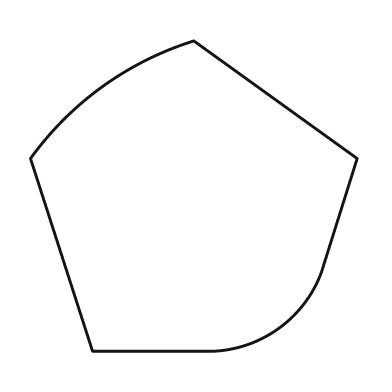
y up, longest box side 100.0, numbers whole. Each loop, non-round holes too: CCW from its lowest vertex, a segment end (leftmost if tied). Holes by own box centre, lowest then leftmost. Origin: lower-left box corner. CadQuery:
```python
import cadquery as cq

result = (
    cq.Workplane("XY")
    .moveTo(19.0, 0.0)
    .lineTo(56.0, 0.0)
    .threePointArc((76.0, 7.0), (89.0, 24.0))
    .lineTo(100.0, 59.0)
    .lineTo(50.0, 95.0)
    .threePointArc((22.0, 81.0), (0.0, 59.0))
    .close()
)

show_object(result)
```